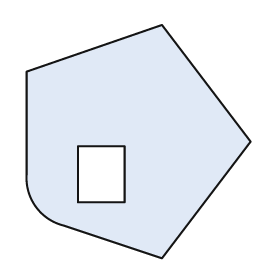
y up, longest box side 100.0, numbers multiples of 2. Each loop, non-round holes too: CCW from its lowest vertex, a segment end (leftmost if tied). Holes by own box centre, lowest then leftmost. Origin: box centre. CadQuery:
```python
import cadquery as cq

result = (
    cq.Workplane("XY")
    .moveTo(10.0, -50.0)
    .lineTo(48.0, 0.0)
    .lineTo(10.0, 50.0)
    .lineTo(-48.0, 30.0)
    .lineTo(-48.0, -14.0)
    .threePointArc((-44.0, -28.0), (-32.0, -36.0))
    .close()
    .moveTo(-26.0, -26.0)
    .lineTo(-6.0, -26.0)
    .lineTo(-6.0, -2.0)
    .lineTo(-26.0, -2.0)
    .close()
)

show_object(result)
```